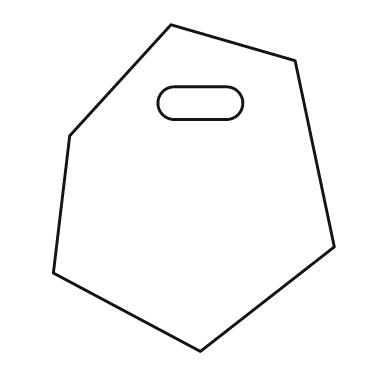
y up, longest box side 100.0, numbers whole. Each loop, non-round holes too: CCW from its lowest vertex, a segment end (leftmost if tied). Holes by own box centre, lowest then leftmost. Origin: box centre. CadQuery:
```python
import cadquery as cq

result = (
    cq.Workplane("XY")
    .moveTo(2.0, -50.0)
    .lineTo(43.0, -18.0)
    .lineTo(31.0, 39.0)
    .lineTo(-7.0, 50.0)
    .lineTo(-38.0, 16.0)
    .lineTo(-43.0, -26.0)
    .close()
    .moveTo(-6.0, 21.0)
    .lineTo(10.0, 21.0)
    .threePointArc((15.0, 26.0), (10.0, 31.0))
    .lineTo(-6.0, 31.0)
    .threePointArc((-11.0, 26.0), (-6.0, 21.0))
    .close()
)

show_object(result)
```